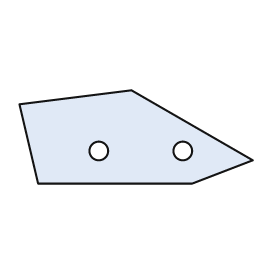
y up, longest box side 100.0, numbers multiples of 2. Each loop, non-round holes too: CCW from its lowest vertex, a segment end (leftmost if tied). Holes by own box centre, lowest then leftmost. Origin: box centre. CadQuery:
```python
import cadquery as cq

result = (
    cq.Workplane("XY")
    .moveTo(-42.0, -20.0)
    .lineTo(24.0, -20.0)
    .lineTo(50.0, -10.0)
    .lineTo(-2.0, 20.0)
    .lineTo(-50.0, 14.0)
    .close()
    .moveTo(-16.0, -6.0)
    .circle(4.0)
    .moveTo(20.0, -6.0)
    .circle(4.0)
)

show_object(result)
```